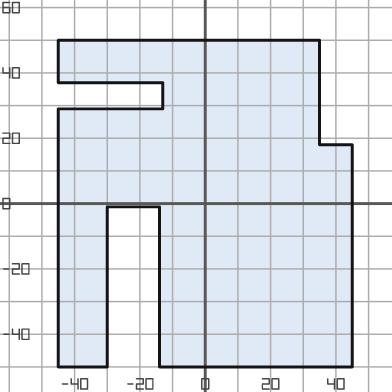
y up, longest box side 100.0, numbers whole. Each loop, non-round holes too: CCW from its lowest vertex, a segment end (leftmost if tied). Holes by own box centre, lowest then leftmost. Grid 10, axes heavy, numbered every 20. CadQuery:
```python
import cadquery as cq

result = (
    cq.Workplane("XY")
    .moveTo(-45.0, -50.0)
    .lineTo(-30.0, -50.0)
    .lineTo(-30.0, -1.0)
    .lineTo(-14.0, -1.0)
    .lineTo(-14.0, -50.0)
    .lineTo(45.0, -50.0)
    .lineTo(45.0, 18.0)
    .lineTo(35.0, 18.0)
    .lineTo(35.0, 50.0)
    .lineTo(-45.0, 50.0)
    .lineTo(-45.0, 37.0)
    .lineTo(-13.0, 37.0)
    .lineTo(-13.0, 29.0)
    .lineTo(-45.0, 29.0)
    .close()
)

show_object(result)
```